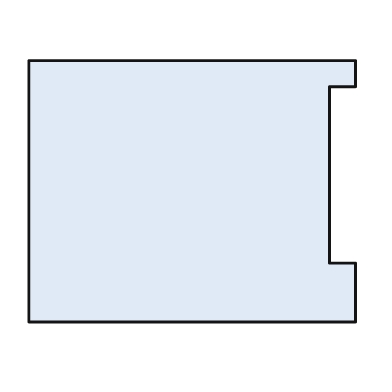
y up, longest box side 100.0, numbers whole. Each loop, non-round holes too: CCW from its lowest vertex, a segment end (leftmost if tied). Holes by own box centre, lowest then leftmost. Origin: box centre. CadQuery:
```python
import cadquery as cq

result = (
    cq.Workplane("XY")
    .moveTo(-50.0, -40.0)
    .lineTo(50.0, -40.0)
    .lineTo(50.0, -22.0)
    .lineTo(42.0, -22.0)
    .lineTo(42.0, 32.0)
    .lineTo(50.0, 32.0)
    .lineTo(50.0, 40.0)
    .lineTo(-50.0, 40.0)
    .close()
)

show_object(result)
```